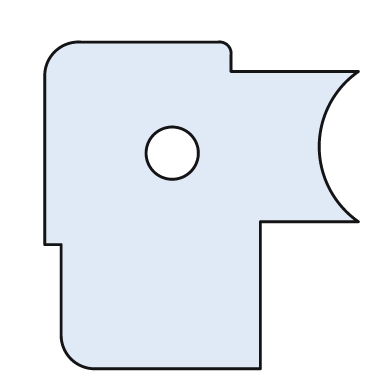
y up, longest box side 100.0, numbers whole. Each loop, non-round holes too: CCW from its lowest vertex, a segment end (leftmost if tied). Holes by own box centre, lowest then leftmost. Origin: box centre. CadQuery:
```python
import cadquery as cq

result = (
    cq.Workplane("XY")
    .moveTo(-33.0, -50.0)
    .lineTo(18.0, -50.0)
    .lineTo(18.0, -5.0)
    .lineTo(48.0, -5.0)
    .threePointArc((36.0, 18.0), (48.0, 41.0))
    .lineTo(9.0, 41.0)
    .lineTo(9.0, 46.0)
    .threePointArc((8.0, 49.0), (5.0, 50.0))
    .lineTo(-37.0, 50.0)
    .threePointArc((-45.0, 47.0), (-48.0, 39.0))
    .lineTo(-48.0, -12.0)
    .lineTo(-43.0, -12.0)
    .lineTo(-43.0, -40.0)
    .threePointArc((-40.0, -47.0), (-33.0, -50.0))
    .close()
    .moveTo(-9.0, 16.0)
    .circle(8.0)
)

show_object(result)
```